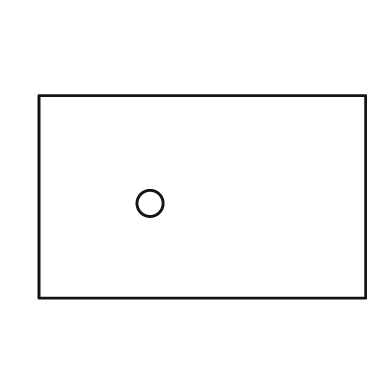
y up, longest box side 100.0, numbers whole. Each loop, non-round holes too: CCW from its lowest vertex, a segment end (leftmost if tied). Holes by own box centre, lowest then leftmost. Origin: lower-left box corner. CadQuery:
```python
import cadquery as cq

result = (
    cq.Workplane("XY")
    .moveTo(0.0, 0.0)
    .lineTo(100.0, 0.0)
    .lineTo(100.0, 62.0)
    .lineTo(0.0, 62.0)
    .close()
    .moveTo(34.0, 29.0)
    .circle(4.0)
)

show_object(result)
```